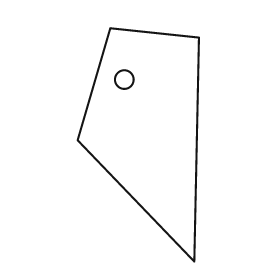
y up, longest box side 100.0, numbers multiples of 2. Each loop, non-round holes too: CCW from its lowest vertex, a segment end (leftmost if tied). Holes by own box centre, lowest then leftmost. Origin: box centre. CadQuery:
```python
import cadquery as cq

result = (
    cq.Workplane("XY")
    .moveTo(24.0, -50.0)
    .lineTo(26.0, 46.0)
    .lineTo(-12.0, 50.0)
    .lineTo(-26.0, 2.0)
    .close()
    .moveTo(-6.0, 28.0)
    .circle(4.0)
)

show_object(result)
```